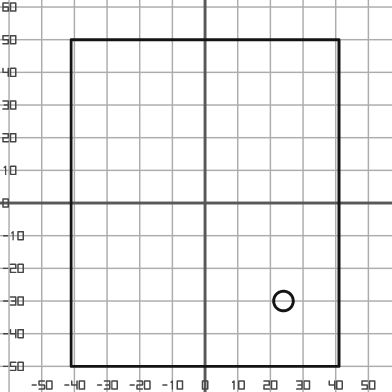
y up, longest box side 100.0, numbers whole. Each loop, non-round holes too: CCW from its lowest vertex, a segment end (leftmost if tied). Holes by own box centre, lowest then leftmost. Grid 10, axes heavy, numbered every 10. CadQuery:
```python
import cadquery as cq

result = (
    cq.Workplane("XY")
    .moveTo(-41.0, -50.0)
    .lineTo(41.0, -50.0)
    .lineTo(41.0, 50.0)
    .lineTo(-41.0, 50.0)
    .close()
    .moveTo(24.0, -30.0)
    .circle(3.0)
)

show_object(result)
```